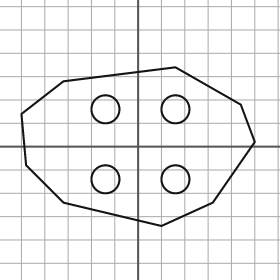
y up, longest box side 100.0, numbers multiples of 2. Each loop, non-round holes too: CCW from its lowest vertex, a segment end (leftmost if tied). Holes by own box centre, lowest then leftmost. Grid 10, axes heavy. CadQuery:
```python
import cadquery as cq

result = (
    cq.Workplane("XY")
    .moveTo(10.0, -34.0)
    .lineTo(32.0, -24.0)
    .lineTo(50.0, 2.0)
    .lineTo(44.0, 18.0)
    .lineTo(16.0, 34.0)
    .lineTo(-32.0, 28.0)
    .lineTo(-50.0, 14.0)
    .lineTo(-48.0, -8.0)
    .lineTo(-32.0, -24.0)
    .close()
    .moveTo(-14.0, -14.0)
    .circle(6.0)
    .moveTo(16.0, -14.0)
    .circle(6.0)
    .moveTo(-14.0, 16.0)
    .circle(6.0)
    .moveTo(16.0, 16.0)
    .circle(6.0)
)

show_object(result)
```